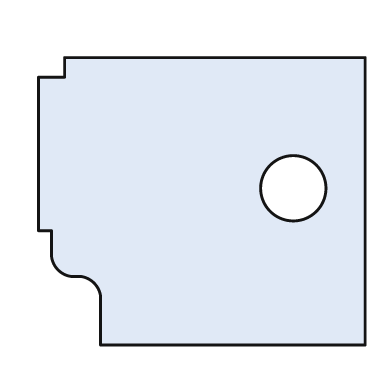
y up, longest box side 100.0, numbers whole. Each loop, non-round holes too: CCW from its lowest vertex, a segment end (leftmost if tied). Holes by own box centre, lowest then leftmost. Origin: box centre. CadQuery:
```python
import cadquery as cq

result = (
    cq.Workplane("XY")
    .moveTo(-31.0, -44.0)
    .lineTo(50.0, -44.0)
    .lineTo(50.0, 44.0)
    .lineTo(-42.0, 44.0)
    .lineTo(-42.0, 38.0)
    .lineTo(-50.0, 38.0)
    .lineTo(-50.0, -9.0)
    .lineTo(-46.0, -9.0)
    .lineTo(-46.0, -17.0)
    .threePointArc((-44.0, -21.0), (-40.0, -23.0))
    .lineTo(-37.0, -23.0)
    .threePointArc((-33.0, -25.0), (-31.0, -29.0))
    .close()
    .moveTo(28.0, 4.0)
    .circle(10.0)
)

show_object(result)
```